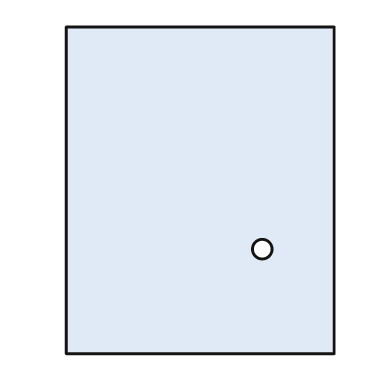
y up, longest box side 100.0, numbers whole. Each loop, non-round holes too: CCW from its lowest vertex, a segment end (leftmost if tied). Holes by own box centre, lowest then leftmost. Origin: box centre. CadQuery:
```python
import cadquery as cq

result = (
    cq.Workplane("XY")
    .moveTo(-41.0, -50.0)
    .lineTo(41.0, -50.0)
    .lineTo(41.0, 50.0)
    .lineTo(-41.0, 50.0)
    .close()
    .moveTo(19.0, -18.0)
    .circle(3.0)
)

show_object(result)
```